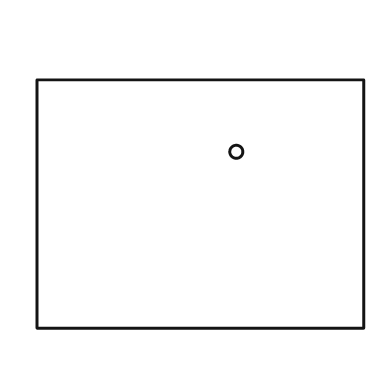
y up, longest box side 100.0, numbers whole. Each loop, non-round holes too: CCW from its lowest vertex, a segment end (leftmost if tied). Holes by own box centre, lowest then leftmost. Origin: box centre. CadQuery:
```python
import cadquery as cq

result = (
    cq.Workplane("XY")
    .moveTo(-50.0, -38.0)
    .lineTo(50.0, -38.0)
    .lineTo(50.0, 38.0)
    .lineTo(-50.0, 38.0)
    .close()
    .moveTo(11.0, 16.0)
    .circle(2.0)
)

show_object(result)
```